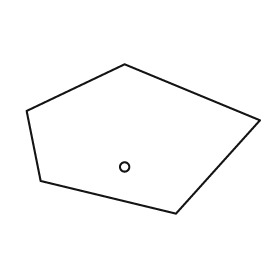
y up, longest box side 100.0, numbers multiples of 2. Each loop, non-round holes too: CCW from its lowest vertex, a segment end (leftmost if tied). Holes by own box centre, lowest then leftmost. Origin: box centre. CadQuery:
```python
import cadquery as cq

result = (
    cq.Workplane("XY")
    .moveTo(14.0, -32.0)
    .lineTo(50.0, 8.0)
    .lineTo(-8.0, 32.0)
    .lineTo(-50.0, 12.0)
    .lineTo(-44.0, -18.0)
    .close()
    .moveTo(-8.0, -12.0)
    .circle(2.0)
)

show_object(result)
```